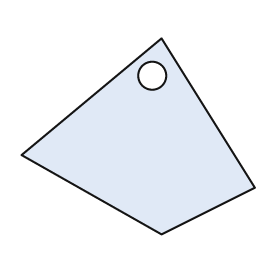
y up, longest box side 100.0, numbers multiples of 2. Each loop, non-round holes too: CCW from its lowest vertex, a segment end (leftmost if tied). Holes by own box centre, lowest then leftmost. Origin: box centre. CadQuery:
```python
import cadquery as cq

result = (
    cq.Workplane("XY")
    .moveTo(10.0, -42.0)
    .lineTo(50.0, -22.0)
    .lineTo(10.0, 42.0)
    .lineTo(-50.0, -8.0)
    .close()
    .moveTo(6.0, 26.0)
    .circle(6.0)
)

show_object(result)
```